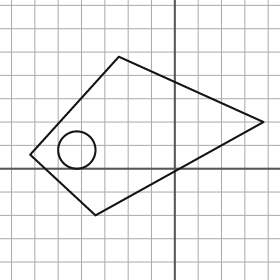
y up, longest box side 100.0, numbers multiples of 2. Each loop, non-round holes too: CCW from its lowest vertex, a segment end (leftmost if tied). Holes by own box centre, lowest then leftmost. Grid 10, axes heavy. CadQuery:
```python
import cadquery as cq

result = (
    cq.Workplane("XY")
    .moveTo(-34.0, -20.0)
    .lineTo(38.0, 20.0)
    .lineTo(-24.0, 48.0)
    .lineTo(-62.0, 6.0)
    .close()
    .moveTo(-42.0, 8.0)
    .circle(8.0)
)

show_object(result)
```